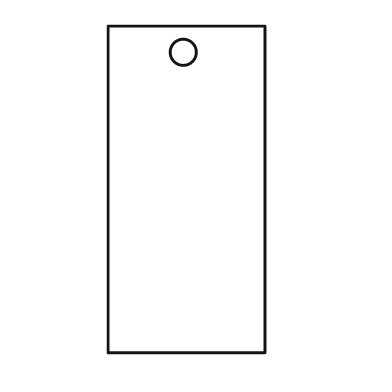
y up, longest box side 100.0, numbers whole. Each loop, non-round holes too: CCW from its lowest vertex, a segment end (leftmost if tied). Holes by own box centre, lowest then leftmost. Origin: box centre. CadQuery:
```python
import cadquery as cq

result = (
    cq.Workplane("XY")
    .moveTo(-24.0, -50.0)
    .lineTo(24.0, -50.0)
    .lineTo(24.0, 50.0)
    .lineTo(-24.0, 50.0)
    .close()
    .moveTo(-1.0, 42.0)
    .circle(4.0)
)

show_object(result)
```